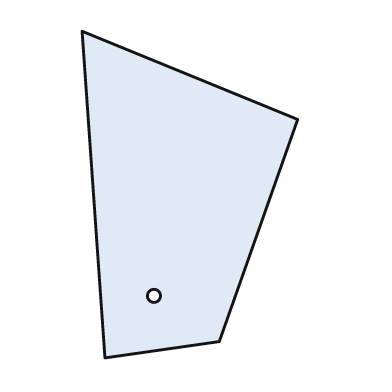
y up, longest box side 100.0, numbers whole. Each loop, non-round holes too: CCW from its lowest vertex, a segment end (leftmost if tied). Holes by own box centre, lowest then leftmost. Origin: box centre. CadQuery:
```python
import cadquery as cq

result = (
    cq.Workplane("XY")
    .moveTo(-26.0, -50.0)
    .lineTo(9.0, -45.0)
    .lineTo(33.0, 23.0)
    .lineTo(-33.0, 50.0)
    .close()
    .moveTo(-11.0, -31.0)
    .circle(2.0)
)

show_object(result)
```